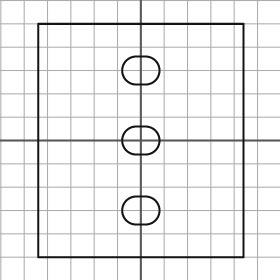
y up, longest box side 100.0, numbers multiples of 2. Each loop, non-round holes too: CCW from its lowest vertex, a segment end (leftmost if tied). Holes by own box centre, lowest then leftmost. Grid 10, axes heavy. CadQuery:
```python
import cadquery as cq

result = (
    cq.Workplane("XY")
    .moveTo(-44.0, -50.0)
    .lineTo(44.0, -50.0)
    .lineTo(44.0, 50.0)
    .lineTo(-44.0, 50.0)
    .close()
    .moveTo(-2.0, -36.0)
    .lineTo(2.0, -36.0)
    .threePointArc((8.0, -30.0), (2.0, -24.0))
    .lineTo(-2.0, -24.0)
    .threePointArc((-8.0, -30.0), (-2.0, -36.0))
    .close()
    .moveTo(-2.0, -6.0)
    .lineTo(2.0, -6.0)
    .threePointArc((8.0, 0.0), (2.0, 6.0))
    .lineTo(-2.0, 6.0)
    .threePointArc((-8.0, 0.0), (-2.0, -6.0))
    .close()
    .moveTo(-2.0, 24.0)
    .lineTo(2.0, 24.0)
    .threePointArc((8.0, 30.0), (2.0, 36.0))
    .lineTo(-2.0, 36.0)
    .threePointArc((-8.0, 30.0), (-2.0, 24.0))
    .close()
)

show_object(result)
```